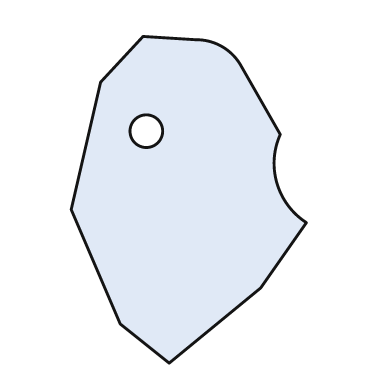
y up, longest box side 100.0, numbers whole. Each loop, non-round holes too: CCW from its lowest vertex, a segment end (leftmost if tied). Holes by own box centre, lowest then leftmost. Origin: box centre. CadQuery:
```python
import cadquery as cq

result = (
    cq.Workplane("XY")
    .moveTo(-6.0, -50.0)
    .lineTo(22.0, -27.0)
    .lineTo(36.0, -7.0)
    .threePointArc((27.0, 5.0), (28.0, 20.0))
    .lineTo(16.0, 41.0)
    .threePointArc((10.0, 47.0), (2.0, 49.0))
    .lineTo(-14.0, 50.0)
    .lineTo(-27.0, 36.0)
    .lineTo(-36.0, -3.0)
    .lineTo(-21.0, -38.0)
    .close()
    .moveTo(-13.0, 21.0)
    .circle(5.0)
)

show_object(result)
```